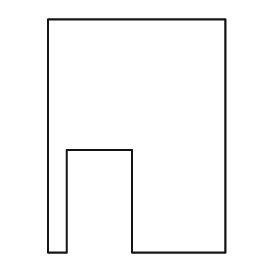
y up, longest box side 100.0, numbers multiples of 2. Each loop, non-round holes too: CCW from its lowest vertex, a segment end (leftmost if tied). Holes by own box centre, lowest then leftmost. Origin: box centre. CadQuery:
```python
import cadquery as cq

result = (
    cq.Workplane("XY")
    .moveTo(-38.0, -50.0)
    .lineTo(-30.0, -50.0)
    .lineTo(-30.0, -6.0)
    .lineTo(-2.0, -6.0)
    .lineTo(-2.0, -50.0)
    .lineTo(38.0, -50.0)
    .lineTo(38.0, 50.0)
    .lineTo(-38.0, 50.0)
    .close()
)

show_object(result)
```